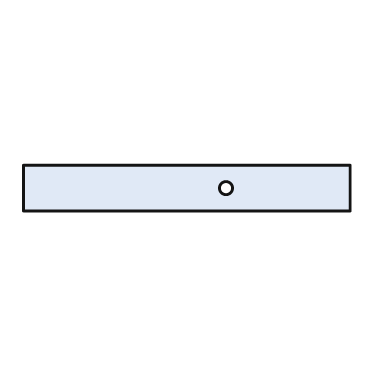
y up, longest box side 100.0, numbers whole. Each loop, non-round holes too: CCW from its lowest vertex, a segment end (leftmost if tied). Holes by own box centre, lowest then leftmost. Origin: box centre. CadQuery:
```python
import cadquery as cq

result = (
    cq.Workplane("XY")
    .moveTo(-50.0, -7.0)
    .lineTo(50.0, -7.0)
    .lineTo(50.0, 7.0)
    .lineTo(-50.0, 7.0)
    .close()
    .moveTo(12.0, 0.0)
    .circle(2.0)
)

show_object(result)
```